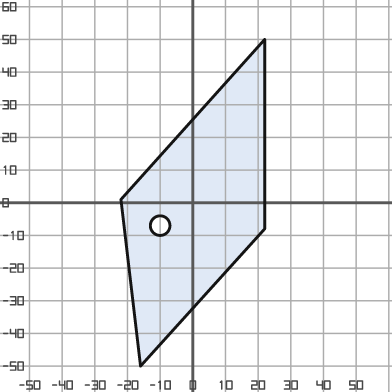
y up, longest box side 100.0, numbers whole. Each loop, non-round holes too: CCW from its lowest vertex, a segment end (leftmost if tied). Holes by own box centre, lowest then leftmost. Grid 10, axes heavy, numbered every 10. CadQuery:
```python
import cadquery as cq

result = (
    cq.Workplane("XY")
    .moveTo(-16.0, -50.0)
    .lineTo(22.0, -8.0)
    .lineTo(22.0, 50.0)
    .lineTo(-22.0, 1.0)
    .close()
    .moveTo(-10.0, -7.0)
    .circle(3.0)
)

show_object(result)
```